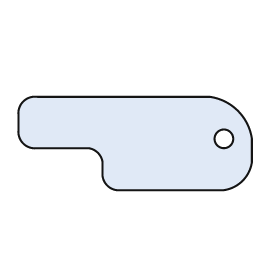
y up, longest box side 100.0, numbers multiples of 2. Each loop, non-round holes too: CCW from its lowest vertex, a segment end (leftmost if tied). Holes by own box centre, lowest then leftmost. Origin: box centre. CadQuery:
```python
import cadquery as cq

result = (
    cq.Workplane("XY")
    .moveTo(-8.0, -20.0)
    .lineTo(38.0, -20.0)
    .threePointArc((46.0, -16.0), (50.0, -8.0))
    .lineTo(50.0, 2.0)
    .threePointArc((44.0, 14.0), (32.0, 20.0))
    .lineTo(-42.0, 20.0)
    .threePointArc((-48.0, 18.0), (-50.0, 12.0))
    .lineTo(-50.0, 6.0)
    .threePointArc((-48.0, 0.0), (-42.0, -2.0))
    .lineTo(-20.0, -2.0)
    .threePointArc((-16.0, -4.0), (-14.0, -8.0))
    .lineTo(-14.0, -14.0)
    .threePointArc((-12.0, -18.0), (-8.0, -20.0))
    .close()
    .moveTo(38.0, 2.0)
    .circle(4.0)
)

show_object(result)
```